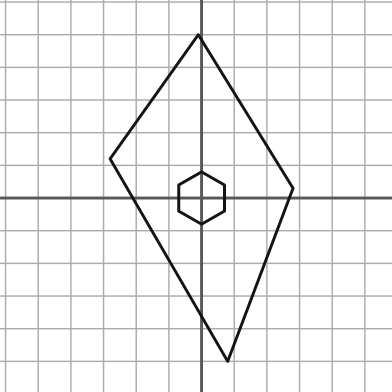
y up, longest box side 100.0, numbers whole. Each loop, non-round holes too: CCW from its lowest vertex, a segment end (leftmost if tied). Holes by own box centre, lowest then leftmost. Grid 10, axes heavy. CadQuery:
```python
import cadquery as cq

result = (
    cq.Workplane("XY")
    .moveTo(8.0, -50.0)
    .lineTo(28.0, 3.0)
    .lineTo(-1.0, 50.0)
    .lineTo(-28.0, 12.0)
    .close()
    .moveTo(0.0, -8.0)
    .lineTo(7.0, -4.0)
    .lineTo(7.0, 4.0)
    .lineTo(0.0, 8.0)
    .lineTo(-7.0, 4.0)
    .lineTo(-7.0, -4.0)
    .close()
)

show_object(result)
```